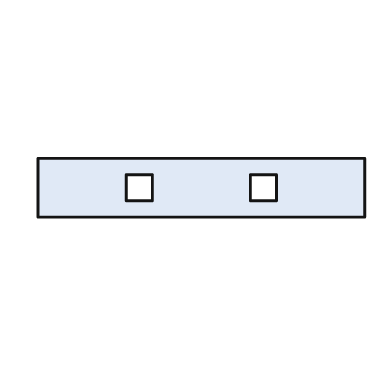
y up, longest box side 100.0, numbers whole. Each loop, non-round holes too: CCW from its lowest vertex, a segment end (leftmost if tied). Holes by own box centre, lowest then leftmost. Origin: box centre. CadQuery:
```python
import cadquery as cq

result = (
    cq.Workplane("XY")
    .moveTo(-50.0, -9.0)
    .lineTo(50.0, -9.0)
    .lineTo(50.0, 9.0)
    .lineTo(-50.0, 9.0)
    .close()
    .moveTo(-23.0, -4.0)
    .lineTo(-15.0, -4.0)
    .lineTo(-15.0, 4.0)
    .lineTo(-23.0, 4.0)
    .close()
    .moveTo(15.0, -4.0)
    .lineTo(23.0, -4.0)
    .lineTo(23.0, 4.0)
    .lineTo(15.0, 4.0)
    .close()
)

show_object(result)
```